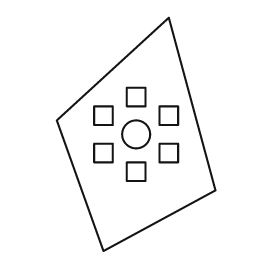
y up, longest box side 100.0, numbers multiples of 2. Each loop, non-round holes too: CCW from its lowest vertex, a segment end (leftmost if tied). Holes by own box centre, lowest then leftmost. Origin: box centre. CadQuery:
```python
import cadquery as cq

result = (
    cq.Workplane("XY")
    .moveTo(-14.0, -50.0)
    .lineTo(34.0, -24.0)
    .lineTo(14.0, 50.0)
    .lineTo(-34.0, 6.0)
    .close()
    .moveTo(-4.0, -20.0)
    .lineTo(4.0, -20.0)
    .lineTo(4.0, -12.0)
    .lineTo(-4.0, -12.0)
    .close()
    .moveTo(-18.0, -12.0)
    .lineTo(-10.0, -12.0)
    .lineTo(-10.0, -4.0)
    .lineTo(-18.0, -4.0)
    .close()
    .moveTo(10.0, -12.0)
    .lineTo(18.0, -12.0)
    .lineTo(18.0, -4.0)
    .lineTo(10.0, -4.0)
    .close()
    .moveTo(0.0, 0.0)
    .circle(6.0)
    .moveTo(-18.0, 4.0)
    .lineTo(-10.0, 4.0)
    .lineTo(-10.0, 12.0)
    .lineTo(-18.0, 12.0)
    .close()
    .moveTo(10.0, 4.0)
    .lineTo(18.0, 4.0)
    .lineTo(18.0, 12.0)
    .lineTo(10.0, 12.0)
    .close()
    .moveTo(-4.0, 12.0)
    .lineTo(4.0, 12.0)
    .lineTo(4.0, 20.0)
    .lineTo(-4.0, 20.0)
    .close()
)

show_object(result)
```